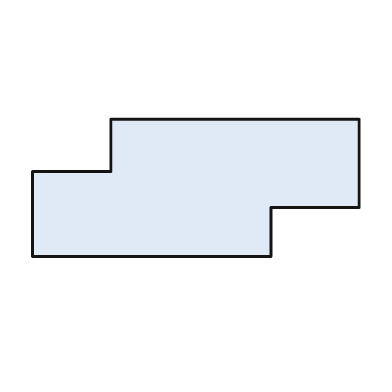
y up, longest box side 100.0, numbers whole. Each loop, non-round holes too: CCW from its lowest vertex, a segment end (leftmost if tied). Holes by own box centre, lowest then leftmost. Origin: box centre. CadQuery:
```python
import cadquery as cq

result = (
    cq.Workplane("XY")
    .moveTo(-50.0, -21.0)
    .lineTo(23.0, -21.0)
    .lineTo(23.0, -6.0)
    .lineTo(50.0, -6.0)
    .lineTo(50.0, 21.0)
    .lineTo(-26.0, 21.0)
    .lineTo(-26.0, 5.0)
    .lineTo(-50.0, 5.0)
    .close()
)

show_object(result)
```